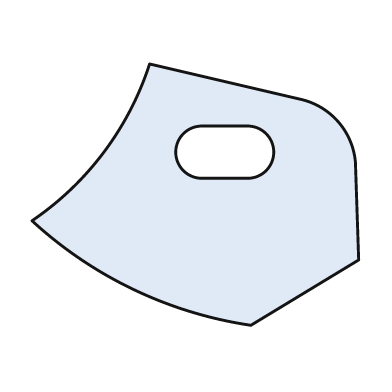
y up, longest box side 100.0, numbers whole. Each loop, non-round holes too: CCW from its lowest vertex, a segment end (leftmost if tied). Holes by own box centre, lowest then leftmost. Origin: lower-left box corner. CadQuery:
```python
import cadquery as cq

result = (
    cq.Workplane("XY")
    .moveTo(67.0, 0.0)
    .lineTo(100.0, 20.0)
    .lineTo(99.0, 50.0)
    .threePointArc((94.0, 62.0), (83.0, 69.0))
    .lineTo(36.0, 80.0)
    .threePointArc((22.0, 53.0), (0.0, 32.0))
    .threePointArc((31.0, 11.0), (67.0, 0.0))
    .close()
    .moveTo(52.0, 45.0)
    .lineTo(66.0, 45.0)
    .threePointArc((74.0, 53.0), (66.0, 61.0))
    .lineTo(52.0, 61.0)
    .threePointArc((44.0, 53.0), (52.0, 45.0))
    .close()
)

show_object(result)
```